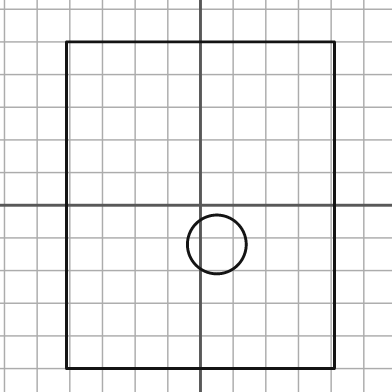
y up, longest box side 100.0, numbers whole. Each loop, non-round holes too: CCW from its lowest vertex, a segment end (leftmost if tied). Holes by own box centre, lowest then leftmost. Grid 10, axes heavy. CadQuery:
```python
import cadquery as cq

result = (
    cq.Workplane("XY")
    .moveTo(-41.0, -50.0)
    .lineTo(41.0, -50.0)
    .lineTo(41.0, 50.0)
    .lineTo(-41.0, 50.0)
    .close()
    .moveTo(5.0, -12.0)
    .circle(9.0)
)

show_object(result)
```